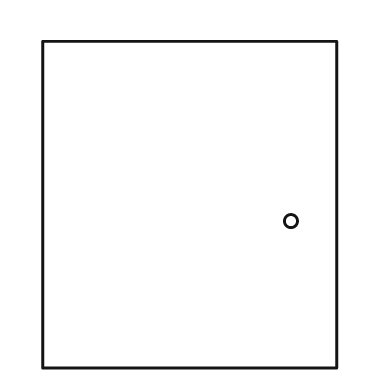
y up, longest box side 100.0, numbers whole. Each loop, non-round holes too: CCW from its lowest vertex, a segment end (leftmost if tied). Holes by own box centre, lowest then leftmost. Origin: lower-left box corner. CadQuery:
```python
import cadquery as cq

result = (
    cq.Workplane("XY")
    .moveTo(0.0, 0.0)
    .lineTo(90.0, 0.0)
    .lineTo(90.0, 100.0)
    .lineTo(0.0, 100.0)
    .close()
    .moveTo(76.0, 45.0)
    .circle(2.0)
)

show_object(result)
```